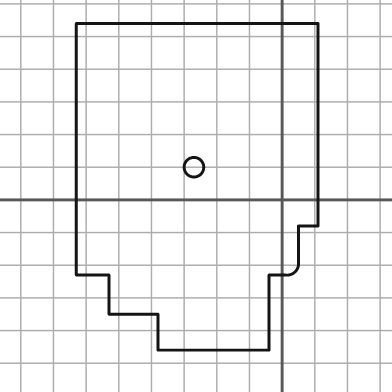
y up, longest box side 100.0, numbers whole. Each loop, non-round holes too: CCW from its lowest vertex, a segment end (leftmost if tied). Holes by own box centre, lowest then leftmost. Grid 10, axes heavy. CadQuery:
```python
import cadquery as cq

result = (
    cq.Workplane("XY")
    .moveTo(-38.0, -46.0)
    .lineTo(-4.0, -46.0)
    .lineTo(-4.0, -23.0)
    .lineTo(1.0, -23.0)
    .threePointArc((4.0, -22.0), (5.0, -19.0))
    .lineTo(5.0, -8.0)
    .lineTo(11.0, -8.0)
    .lineTo(11.0, 54.0)
    .lineTo(-63.0, 54.0)
    .lineTo(-63.0, -23.0)
    .lineTo(-53.0, -23.0)
    .lineTo(-53.0, -35.0)
    .lineTo(-38.0, -35.0)
    .close()
    .moveTo(-27.0, 10.0)
    .circle(3.0)
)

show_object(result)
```